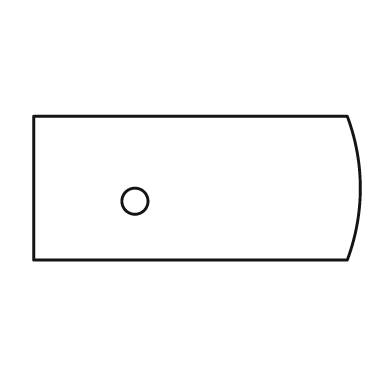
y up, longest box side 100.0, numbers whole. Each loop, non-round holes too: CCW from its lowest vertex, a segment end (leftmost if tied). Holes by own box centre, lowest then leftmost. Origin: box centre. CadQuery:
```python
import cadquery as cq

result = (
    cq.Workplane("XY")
    .moveTo(-50.0, -22.0)
    .lineTo(46.0, -22.0)
    .threePointArc((50.0, 0.0), (46.0, 22.0))
    .lineTo(-50.0, 22.0)
    .close()
    .moveTo(-19.0, -4.0)
    .circle(4.0)
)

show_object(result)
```